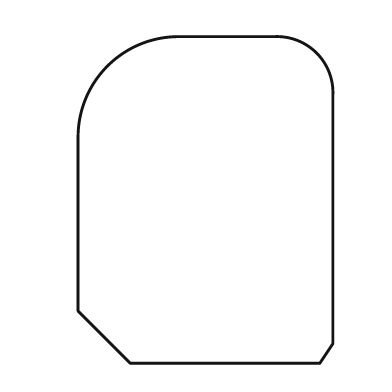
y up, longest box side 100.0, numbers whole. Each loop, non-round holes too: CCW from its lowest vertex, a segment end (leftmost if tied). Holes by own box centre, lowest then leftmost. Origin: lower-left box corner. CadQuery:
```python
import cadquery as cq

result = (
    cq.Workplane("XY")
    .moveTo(16.0, 0.0)
    .lineTo(74.0, 0.0)
    .lineTo(78.0, 6.0)
    .lineTo(78.0, 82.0)
    .threePointArc((73.0, 95.0), (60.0, 100.0))
    .lineTo(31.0, 100.0)
    .threePointArc((9.0, 91.0), (0.0, 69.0))
    .lineTo(0.0, 16.0)
    .close()
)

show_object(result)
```